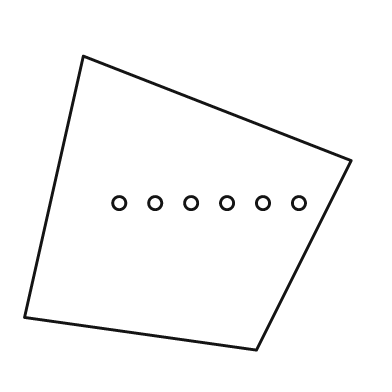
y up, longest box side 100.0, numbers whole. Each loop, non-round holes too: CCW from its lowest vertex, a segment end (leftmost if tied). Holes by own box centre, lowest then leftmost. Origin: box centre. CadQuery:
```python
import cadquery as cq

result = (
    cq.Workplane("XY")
    .moveTo(21.0, -45.0)
    .lineTo(50.0, 13.0)
    .lineTo(-32.0, 45.0)
    .lineTo(-50.0, -35.0)
    .close()
    .moveTo(-21.0, 0.0)
    .circle(2.0)
    .moveTo(-10.0, 0.0)
    .circle(2.0)
    .moveTo(1.0, 0.0)
    .circle(2.0)
    .moveTo(12.0, 0.0)
    .circle(2.0)
    .moveTo(23.0, 0.0)
    .circle(2.0)
    .moveTo(34.0, 0.0)
    .circle(2.0)
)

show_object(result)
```